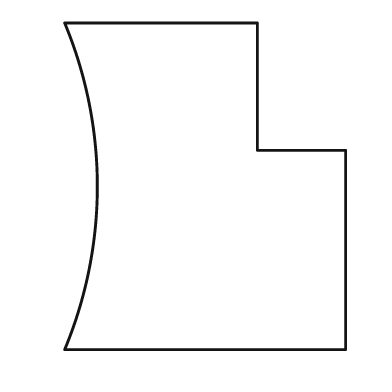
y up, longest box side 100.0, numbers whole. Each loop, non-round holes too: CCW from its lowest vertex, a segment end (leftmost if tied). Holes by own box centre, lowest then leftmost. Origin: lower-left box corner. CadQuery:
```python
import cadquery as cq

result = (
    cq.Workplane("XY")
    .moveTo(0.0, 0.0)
    .lineTo(86.0, 0.0)
    .lineTo(86.0, 61.0)
    .lineTo(59.0, 61.0)
    .lineTo(59.0, 100.0)
    .lineTo(0.0, 100.0)
    .threePointArc((10.0, 50.0), (0.0, 0.0))
    .close()
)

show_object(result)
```